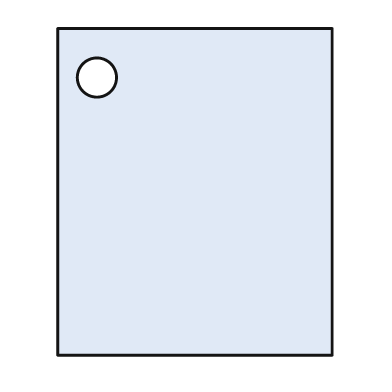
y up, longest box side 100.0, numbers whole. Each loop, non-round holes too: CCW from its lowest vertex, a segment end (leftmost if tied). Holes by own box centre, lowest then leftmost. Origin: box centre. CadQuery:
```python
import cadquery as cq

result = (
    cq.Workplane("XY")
    .moveTo(-42.0, -50.0)
    .lineTo(42.0, -50.0)
    .lineTo(42.0, 50.0)
    .lineTo(-42.0, 50.0)
    .close()
    .moveTo(-30.0, 35.0)
    .circle(6.0)
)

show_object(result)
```